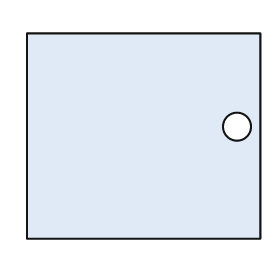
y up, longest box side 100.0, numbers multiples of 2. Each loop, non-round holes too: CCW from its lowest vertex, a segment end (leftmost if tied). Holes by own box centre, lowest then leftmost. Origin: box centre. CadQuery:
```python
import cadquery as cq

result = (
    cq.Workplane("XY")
    .moveTo(-50.0, -44.0)
    .lineTo(50.0, -44.0)
    .lineTo(50.0, 44.0)
    .lineTo(-50.0, 44.0)
    .close()
    .moveTo(40.0, 4.0)
    .circle(6.0)
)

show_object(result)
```